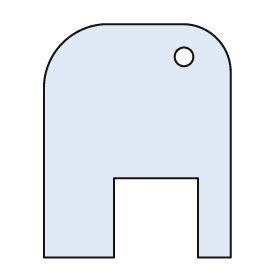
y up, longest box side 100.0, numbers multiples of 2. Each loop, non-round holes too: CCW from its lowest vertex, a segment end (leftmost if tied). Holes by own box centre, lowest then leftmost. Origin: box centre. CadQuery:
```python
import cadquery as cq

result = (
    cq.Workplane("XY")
    .moveTo(-40.0, -50.0)
    .lineTo(-10.0, -50.0)
    .lineTo(-10.0, -16.0)
    .lineTo(26.0, -16.0)
    .lineTo(26.0, -50.0)
    .lineTo(40.0, -50.0)
    .lineTo(40.0, 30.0)
    .threePointArc((34.0, 44.0), (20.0, 50.0))
    .lineTo(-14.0, 50.0)
    .threePointArc((-32.0, 42.0), (-40.0, 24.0))
    .close()
    .moveTo(20.0, 36.0)
    .circle(4.0)
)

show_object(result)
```